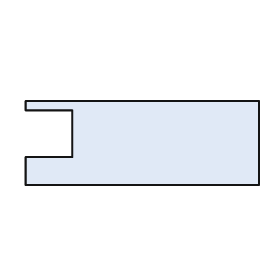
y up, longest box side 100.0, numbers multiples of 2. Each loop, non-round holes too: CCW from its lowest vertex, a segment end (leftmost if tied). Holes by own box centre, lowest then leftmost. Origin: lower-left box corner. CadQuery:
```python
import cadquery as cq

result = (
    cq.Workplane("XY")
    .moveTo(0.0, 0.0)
    .lineTo(100.0, 0.0)
    .lineTo(100.0, 36.0)
    .lineTo(0.0, 36.0)
    .lineTo(0.0, 32.0)
    .lineTo(20.0, 32.0)
    .lineTo(20.0, 12.0)
    .lineTo(0.0, 12.0)
    .close()
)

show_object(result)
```